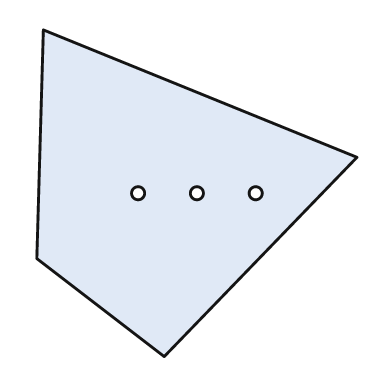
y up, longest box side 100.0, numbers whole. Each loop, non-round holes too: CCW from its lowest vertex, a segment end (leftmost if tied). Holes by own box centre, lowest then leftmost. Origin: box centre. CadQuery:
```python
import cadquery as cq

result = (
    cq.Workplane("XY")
    .moveTo(-10.0, -50.0)
    .lineTo(49.0, 11.0)
    .lineTo(-47.0, 50.0)
    .lineTo(-49.0, -20.0)
    .close()
    .moveTo(-18.0, 0.0)
    .circle(2.0)
    .moveTo(0.0, 0.0)
    .circle(2.0)
    .moveTo(18.0, 0.0)
    .circle(2.0)
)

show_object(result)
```